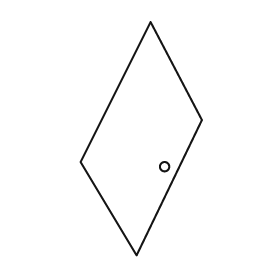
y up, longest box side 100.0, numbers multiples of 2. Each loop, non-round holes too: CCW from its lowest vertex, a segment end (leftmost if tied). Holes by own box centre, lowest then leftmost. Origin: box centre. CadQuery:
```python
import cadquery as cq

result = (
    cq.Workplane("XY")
    .moveTo(-2.0, -50.0)
    .lineTo(26.0, 8.0)
    .lineTo(4.0, 50.0)
    .lineTo(-26.0, -10.0)
    .close()
    .moveTo(10.0, -12.0)
    .circle(2.0)
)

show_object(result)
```